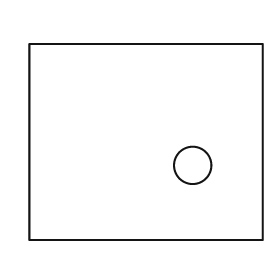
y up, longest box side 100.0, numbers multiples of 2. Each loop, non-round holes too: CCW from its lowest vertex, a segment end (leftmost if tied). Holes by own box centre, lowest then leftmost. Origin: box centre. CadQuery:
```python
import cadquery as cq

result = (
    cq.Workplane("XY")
    .moveTo(-50.0, -42.0)
    .lineTo(50.0, -42.0)
    .lineTo(50.0, 42.0)
    .lineTo(-50.0, 42.0)
    .close()
    .moveTo(20.0, -10.0)
    .circle(8.0)
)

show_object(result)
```